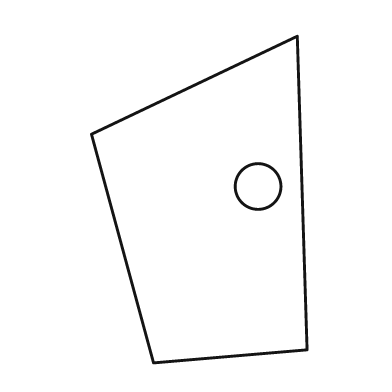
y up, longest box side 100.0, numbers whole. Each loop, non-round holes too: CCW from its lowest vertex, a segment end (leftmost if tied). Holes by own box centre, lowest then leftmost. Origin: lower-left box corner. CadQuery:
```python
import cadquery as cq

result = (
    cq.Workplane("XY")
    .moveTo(19.0, 0.0)
    .lineTo(66.0, 4.0)
    .lineTo(63.0, 100.0)
    .lineTo(0.0, 70.0)
    .close()
    .moveTo(51.0, 54.0)
    .circle(7.0)
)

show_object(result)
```